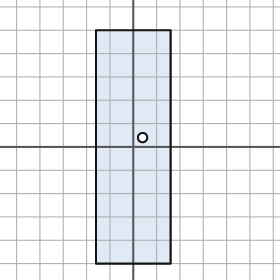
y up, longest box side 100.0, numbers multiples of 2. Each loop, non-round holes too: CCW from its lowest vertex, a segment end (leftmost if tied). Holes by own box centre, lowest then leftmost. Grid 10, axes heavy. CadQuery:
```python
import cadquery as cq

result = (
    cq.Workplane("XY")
    .moveTo(-16.0, -50.0)
    .lineTo(16.0, -50.0)
    .lineTo(16.0, 50.0)
    .lineTo(-16.0, 50.0)
    .close()
    .moveTo(4.0, 4.0)
    .circle(2.0)
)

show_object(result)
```